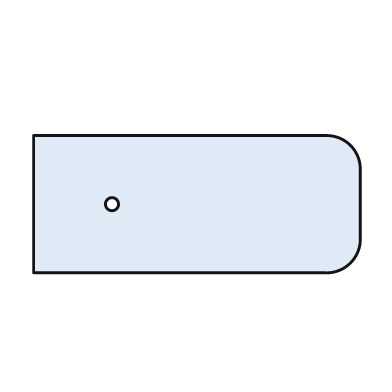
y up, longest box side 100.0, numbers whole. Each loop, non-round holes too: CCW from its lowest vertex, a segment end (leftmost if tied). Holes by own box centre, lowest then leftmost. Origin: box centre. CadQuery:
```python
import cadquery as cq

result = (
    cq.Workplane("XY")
    .moveTo(-50.0, -21.0)
    .lineTo(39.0, -21.0)
    .threePointArc((47.0, -18.0), (50.0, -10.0))
    .lineTo(50.0, 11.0)
    .threePointArc((47.0, 18.0), (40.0, 21.0))
    .lineTo(-50.0, 21.0)
    .close()
    .moveTo(-26.0, 0.0)
    .circle(2.0)
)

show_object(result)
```